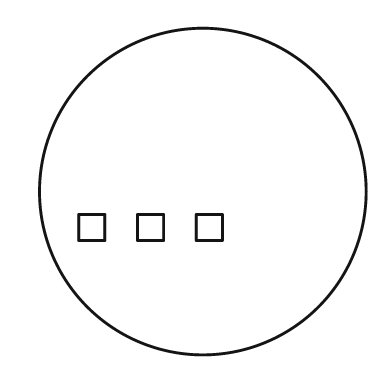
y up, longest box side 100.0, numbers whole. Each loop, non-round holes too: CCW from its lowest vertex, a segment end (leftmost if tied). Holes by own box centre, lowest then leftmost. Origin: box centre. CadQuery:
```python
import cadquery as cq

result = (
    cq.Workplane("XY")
    .moveTo(0.0, 0.0)
    .circle(50.0)
    .moveTo(-38.0, -15.0)
    .lineTo(-30.0, -15.0)
    .lineTo(-30.0, -7.0)
    .lineTo(-38.0, -7.0)
    .close()
    .moveTo(-20.0, -15.0)
    .lineTo(-12.0, -15.0)
    .lineTo(-12.0, -7.0)
    .lineTo(-20.0, -7.0)
    .close()
    .moveTo(-2.0, -15.0)
    .lineTo(6.0, -15.0)
    .lineTo(6.0, -7.0)
    .lineTo(-2.0, -7.0)
    .close()
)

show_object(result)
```